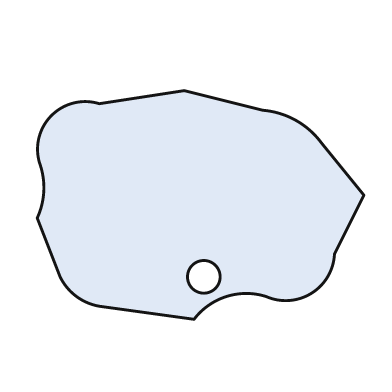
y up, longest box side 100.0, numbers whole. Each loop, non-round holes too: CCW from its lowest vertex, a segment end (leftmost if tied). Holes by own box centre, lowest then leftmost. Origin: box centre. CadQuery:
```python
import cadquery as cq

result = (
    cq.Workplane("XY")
    .moveTo(-2.0, -35.0)
    .threePointArc((8.0, -28.0), (20.0, -28.0))
    .threePointArc((34.0, -27.0), (41.0, -15.0))
    .lineTo(50.0, 3.0)
    .lineTo(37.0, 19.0)
    .threePointArc((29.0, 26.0), (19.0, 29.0))
    .lineTo(-5.0, 35.0)
    .lineTo(-31.0, 31.0)
    .threePointArc((-46.0, 27.0), (-49.0, 12.0))
    .threePointArc((-48.0, 4.0), (-50.0, -4.0))
    .lineTo(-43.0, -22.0)
    .threePointArc((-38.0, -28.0), (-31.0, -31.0))
    .close()
    .moveTo(1.0, -22.0)
    .circle(5.0)
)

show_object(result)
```